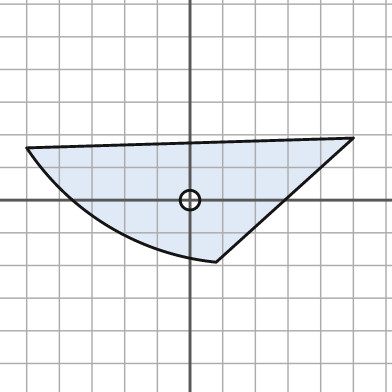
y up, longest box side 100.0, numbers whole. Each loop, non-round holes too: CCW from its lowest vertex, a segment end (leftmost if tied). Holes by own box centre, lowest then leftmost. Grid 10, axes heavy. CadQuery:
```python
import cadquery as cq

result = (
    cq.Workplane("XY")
    .moveTo(8.0, -19.0)
    .lineTo(50.0, 19.0)
    .lineTo(-50.0, 16.0)
    .threePointArc((-25.0, -8.0), (8.0, -19.0))
    .close()
    .moveTo(0.0, 0.0)
    .circle(3.0)
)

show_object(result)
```